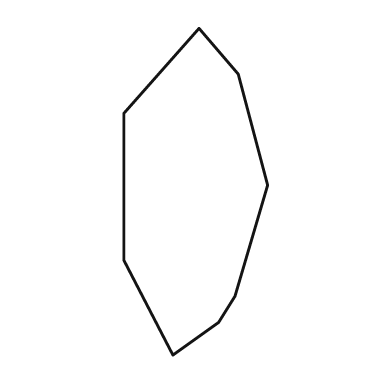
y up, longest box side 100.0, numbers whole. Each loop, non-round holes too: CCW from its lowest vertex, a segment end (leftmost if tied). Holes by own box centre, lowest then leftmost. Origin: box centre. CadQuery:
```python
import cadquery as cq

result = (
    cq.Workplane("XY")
    .moveTo(-7.0, -50.0)
    .lineTo(7.0, -40.0)
    .lineTo(12.0, -32.0)
    .lineTo(22.0, 2.0)
    .lineTo(13.0, 36.0)
    .lineTo(1.0, 50.0)
    .lineTo(-22.0, 24.0)
    .lineTo(-22.0, -21.0)
    .close()
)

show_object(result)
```